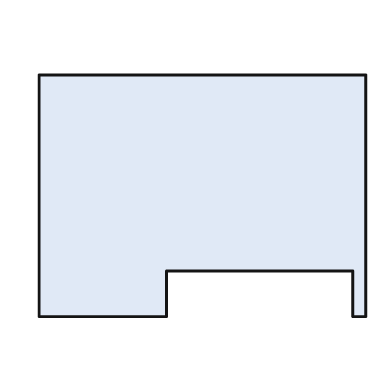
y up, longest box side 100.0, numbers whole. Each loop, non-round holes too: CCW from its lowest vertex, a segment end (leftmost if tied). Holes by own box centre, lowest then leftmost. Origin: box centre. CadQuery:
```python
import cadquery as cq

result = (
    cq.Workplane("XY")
    .moveTo(-50.0, -37.0)
    .lineTo(-11.0, -37.0)
    .lineTo(-11.0, -23.0)
    .lineTo(46.0, -23.0)
    .lineTo(46.0, -37.0)
    .lineTo(50.0, -37.0)
    .lineTo(50.0, 37.0)
    .lineTo(-50.0, 37.0)
    .close()
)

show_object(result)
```